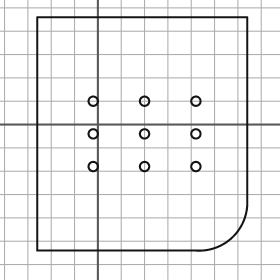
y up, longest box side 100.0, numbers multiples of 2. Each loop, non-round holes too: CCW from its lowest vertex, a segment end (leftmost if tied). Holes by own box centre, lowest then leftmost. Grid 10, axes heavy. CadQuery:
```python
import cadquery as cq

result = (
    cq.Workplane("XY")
    .moveTo(-26.0, -54.0)
    .lineTo(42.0, -54.0)
    .threePointArc((58.0, -48.0), (64.0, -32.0))
    .lineTo(64.0, 46.0)
    .lineTo(-26.0, 46.0)
    .close()
    .moveTo(-2.0, -18.0)
    .circle(2.0)
    .moveTo(20.0, -18.0)
    .circle(2.0)
    .moveTo(42.0, -18.0)
    .circle(2.0)
    .moveTo(-2.0, -4.0)
    .circle(2.0)
    .moveTo(20.0, -4.0)
    .circle(2.0)
    .moveTo(42.0, -4.0)
    .circle(2.0)
    .moveTo(-2.0, 10.0)
    .circle(2.0)
    .moveTo(20.0, 10.0)
    .circle(2.0)
    .moveTo(42.0, 10.0)
    .circle(2.0)
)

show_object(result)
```